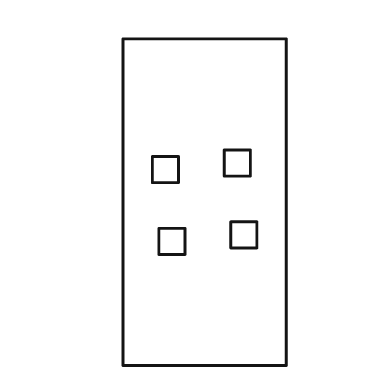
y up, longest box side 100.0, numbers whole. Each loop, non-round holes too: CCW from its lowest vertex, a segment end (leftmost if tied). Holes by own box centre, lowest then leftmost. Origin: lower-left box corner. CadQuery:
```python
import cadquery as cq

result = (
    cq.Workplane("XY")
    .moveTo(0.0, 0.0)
    .lineTo(50.0, 0.0)
    .lineTo(50.0, 100.0)
    .lineTo(0.0, 100.0)
    .close()
    .moveTo(11.0, 34.0)
    .lineTo(19.0, 34.0)
    .lineTo(19.0, 42.0)
    .lineTo(11.0, 42.0)
    .close()
    .moveTo(33.0, 36.0)
    .lineTo(41.0, 36.0)
    .lineTo(41.0, 44.0)
    .lineTo(33.0, 44.0)
    .close()
    .moveTo(9.0, 56.0)
    .lineTo(17.0, 56.0)
    .lineTo(17.0, 64.0)
    .lineTo(9.0, 64.0)
    .close()
    .moveTo(31.0, 58.0)
    .lineTo(39.0, 58.0)
    .lineTo(39.0, 66.0)
    .lineTo(31.0, 66.0)
    .close()
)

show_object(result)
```